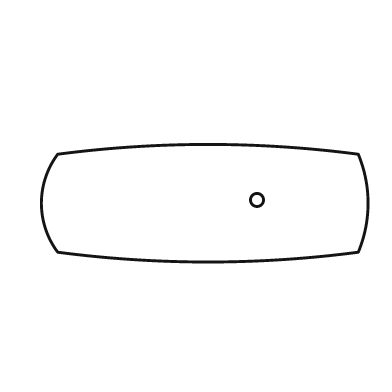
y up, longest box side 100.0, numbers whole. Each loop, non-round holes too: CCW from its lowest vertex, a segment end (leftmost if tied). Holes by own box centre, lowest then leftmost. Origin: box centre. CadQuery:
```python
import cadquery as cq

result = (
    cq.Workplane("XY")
    .moveTo(-45.0, -15.0)
    .threePointArc((1.0, -18.0), (47.0, -15.0))
    .threePointArc((50.0, 0.0), (47.0, 15.0))
    .threePointArc((1.0, 18.0), (-45.0, 15.0))
    .threePointArc((-50.0, 0.0), (-45.0, -15.0))
    .close()
    .moveTo(16.0, 1.0)
    .circle(2.0)
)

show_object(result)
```